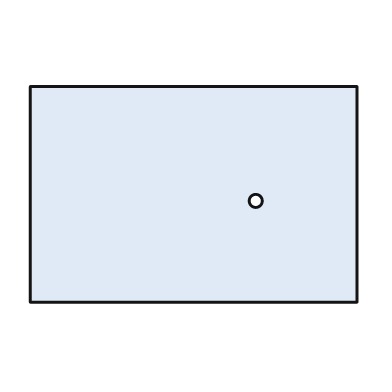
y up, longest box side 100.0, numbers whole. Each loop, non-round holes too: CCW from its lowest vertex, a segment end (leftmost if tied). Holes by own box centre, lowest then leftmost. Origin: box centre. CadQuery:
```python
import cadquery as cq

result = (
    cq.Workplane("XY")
    .moveTo(-50.0, -33.0)
    .lineTo(50.0, -33.0)
    .lineTo(50.0, 33.0)
    .lineTo(-50.0, 33.0)
    .close()
    .moveTo(19.0, -2.0)
    .circle(2.0)
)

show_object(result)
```